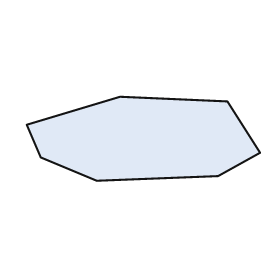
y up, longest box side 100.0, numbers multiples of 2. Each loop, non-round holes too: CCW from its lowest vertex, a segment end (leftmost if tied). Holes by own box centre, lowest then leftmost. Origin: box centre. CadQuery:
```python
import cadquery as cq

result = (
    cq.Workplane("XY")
    .moveTo(-20.0, -18.0)
    .lineTo(32.0, -16.0)
    .lineTo(50.0, -6.0)
    .lineTo(36.0, 16.0)
    .lineTo(-10.0, 18.0)
    .lineTo(-50.0, 6.0)
    .lineTo(-44.0, -8.0)
    .close()
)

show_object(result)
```